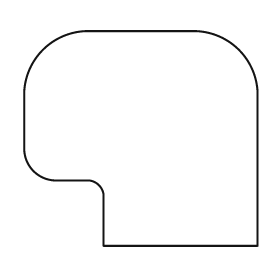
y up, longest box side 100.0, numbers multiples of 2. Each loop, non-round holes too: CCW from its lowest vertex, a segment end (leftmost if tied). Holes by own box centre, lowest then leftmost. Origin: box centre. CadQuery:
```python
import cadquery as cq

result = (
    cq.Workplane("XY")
    .moveTo(-16.0, -46.0)
    .lineTo(50.0, -46.0)
    .lineTo(50.0, 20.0)
    .threePointArc((42.0, 38.0), (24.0, 46.0))
    .lineTo(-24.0, 46.0)
    .threePointArc((-42.0, 38.0), (-50.0, 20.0))
    .lineTo(-50.0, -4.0)
    .threePointArc((-46.0, -14.0), (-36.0, -18.0))
    .lineTo(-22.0, -18.0)
    .threePointArc((-18.0, -20.0), (-16.0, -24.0))
    .close()
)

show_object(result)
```